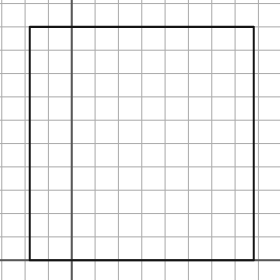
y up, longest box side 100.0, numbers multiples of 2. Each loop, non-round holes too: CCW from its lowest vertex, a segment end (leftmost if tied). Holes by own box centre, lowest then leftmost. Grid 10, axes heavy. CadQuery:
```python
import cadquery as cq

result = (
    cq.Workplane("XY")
    .moveTo(-18.0, 0.0)
    .lineTo(78.0, 0.0)
    .lineTo(78.0, 100.0)
    .lineTo(-18.0, 100.0)
    .close()
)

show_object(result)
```